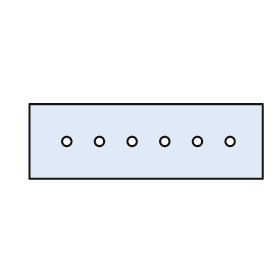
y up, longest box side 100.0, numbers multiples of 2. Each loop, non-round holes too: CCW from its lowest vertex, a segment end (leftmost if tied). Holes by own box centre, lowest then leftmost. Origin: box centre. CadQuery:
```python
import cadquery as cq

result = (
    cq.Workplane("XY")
    .moveTo(-50.0, -16.0)
    .lineTo(50.0, -16.0)
    .lineTo(50.0, 16.0)
    .lineTo(-50.0, 16.0)
    .close()
    .moveTo(-34.0, 0.0)
    .circle(2.0)
    .moveTo(-20.0, 0.0)
    .circle(2.0)
    .moveTo(-6.0, 0.0)
    .circle(2.0)
    .moveTo(8.0, 0.0)
    .circle(2.0)
    .moveTo(22.0, 0.0)
    .circle(2.0)
    .moveTo(36.0, 0.0)
    .circle(2.0)
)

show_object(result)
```